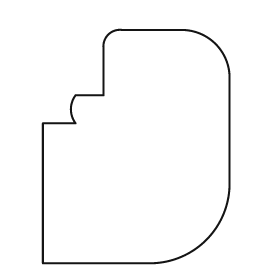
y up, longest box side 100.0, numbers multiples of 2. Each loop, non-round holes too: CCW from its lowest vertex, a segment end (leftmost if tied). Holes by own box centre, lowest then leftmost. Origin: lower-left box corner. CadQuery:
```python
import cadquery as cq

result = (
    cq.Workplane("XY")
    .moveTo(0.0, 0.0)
    .lineTo(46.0, 0.0)
    .threePointArc((70.0, 10.0), (80.0, 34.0))
    .lineTo(80.0, 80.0)
    .threePointArc((74.0, 94.0), (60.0, 100.0))
    .lineTo(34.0, 100.0)
    .threePointArc((28.0, 98.0), (26.0, 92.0))
    .lineTo(26.0, 72.0)
    .lineTo(14.0, 72.0)
    .threePointArc((12.0, 66.0), (14.0, 60.0))
    .lineTo(0.0, 60.0)
    .close()
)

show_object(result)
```